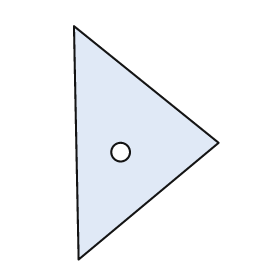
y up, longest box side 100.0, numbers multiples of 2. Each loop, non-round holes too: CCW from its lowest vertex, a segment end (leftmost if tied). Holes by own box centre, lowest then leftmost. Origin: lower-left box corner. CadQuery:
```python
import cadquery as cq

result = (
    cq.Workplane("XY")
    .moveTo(2.0, 0.0)
    .lineTo(62.0, 50.0)
    .lineTo(0.0, 100.0)
    .close()
    .moveTo(20.0, 46.0)
    .circle(4.0)
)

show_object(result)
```